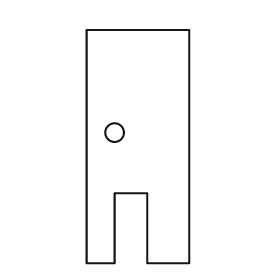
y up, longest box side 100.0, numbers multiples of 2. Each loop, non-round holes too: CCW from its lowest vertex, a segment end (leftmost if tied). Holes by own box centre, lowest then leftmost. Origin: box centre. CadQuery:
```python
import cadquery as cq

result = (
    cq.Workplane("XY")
    .moveTo(-22.0, -50.0)
    .lineTo(-10.0, -50.0)
    .lineTo(-10.0, -20.0)
    .lineTo(4.0, -20.0)
    .lineTo(4.0, -50.0)
    .lineTo(22.0, -50.0)
    .lineTo(22.0, 50.0)
    .lineTo(-22.0, 50.0)
    .close()
    .moveTo(-10.0, 6.0)
    .circle(4.0)
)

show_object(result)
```